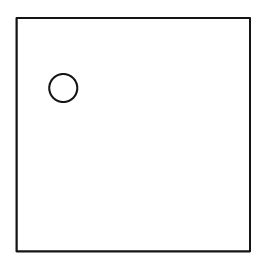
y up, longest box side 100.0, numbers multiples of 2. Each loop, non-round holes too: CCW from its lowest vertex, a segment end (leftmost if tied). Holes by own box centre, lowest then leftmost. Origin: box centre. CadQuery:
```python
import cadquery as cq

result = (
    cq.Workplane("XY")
    .moveTo(-50.0, -50.0)
    .lineTo(50.0, -50.0)
    .lineTo(50.0, 50.0)
    .lineTo(-50.0, 50.0)
    .close()
    .moveTo(-30.0, 20.0)
    .circle(6.0)
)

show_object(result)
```